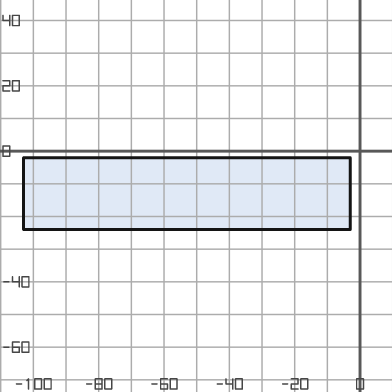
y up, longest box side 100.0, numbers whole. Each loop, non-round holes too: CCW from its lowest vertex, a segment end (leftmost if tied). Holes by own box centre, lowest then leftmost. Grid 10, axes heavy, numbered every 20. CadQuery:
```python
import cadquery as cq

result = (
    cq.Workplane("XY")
    .moveTo(-103.0, -24.0)
    .lineTo(-3.0, -24.0)
    .lineTo(-3.0, -2.0)
    .lineTo(-103.0, -2.0)
    .close()
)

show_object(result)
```